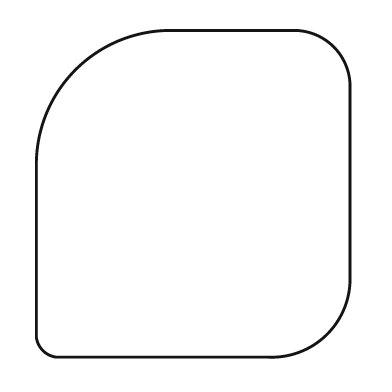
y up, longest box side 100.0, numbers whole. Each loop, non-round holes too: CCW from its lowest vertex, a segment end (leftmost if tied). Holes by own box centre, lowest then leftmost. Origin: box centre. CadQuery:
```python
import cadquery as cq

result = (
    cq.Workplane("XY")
    .moveTo(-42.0, -50.0)
    .lineTo(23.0, -50.0)
    .threePointArc((41.0, -43.0), (48.0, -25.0))
    .lineTo(48.0, 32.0)
    .threePointArc((43.0, 45.0), (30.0, 50.0))
    .lineTo(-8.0, 50.0)
    .threePointArc((-36.0, 38.0), (-48.0, 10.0))
    .lineTo(-48.0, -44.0)
    .threePointArc((-46.0, -48.0), (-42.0, -50.0))
    .close()
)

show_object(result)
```